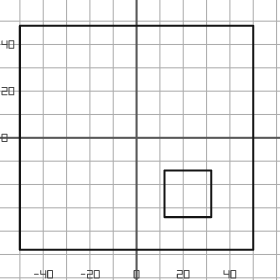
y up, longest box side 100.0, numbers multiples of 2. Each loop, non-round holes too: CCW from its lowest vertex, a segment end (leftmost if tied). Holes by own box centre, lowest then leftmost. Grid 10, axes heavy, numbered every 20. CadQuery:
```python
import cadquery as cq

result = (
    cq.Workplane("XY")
    .moveTo(-50.0, -48.0)
    .lineTo(50.0, -48.0)
    .lineTo(50.0, 48.0)
    .lineTo(-50.0, 48.0)
    .close()
    .moveTo(12.0, -34.0)
    .lineTo(32.0, -34.0)
    .lineTo(32.0, -14.0)
    .lineTo(12.0, -14.0)
    .close()
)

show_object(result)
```